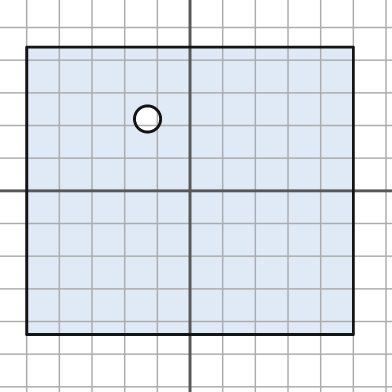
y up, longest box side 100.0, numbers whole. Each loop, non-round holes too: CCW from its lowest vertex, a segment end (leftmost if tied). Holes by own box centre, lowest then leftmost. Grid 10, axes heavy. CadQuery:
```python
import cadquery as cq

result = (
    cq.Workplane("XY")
    .moveTo(-50.0, -44.0)
    .lineTo(50.0, -44.0)
    .lineTo(50.0, 44.0)
    .lineTo(-50.0, 44.0)
    .close()
    .moveTo(-13.0, 22.0)
    .circle(4.0)
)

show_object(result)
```